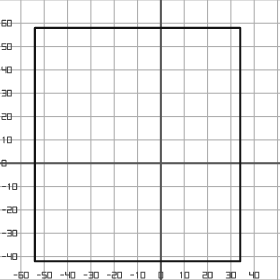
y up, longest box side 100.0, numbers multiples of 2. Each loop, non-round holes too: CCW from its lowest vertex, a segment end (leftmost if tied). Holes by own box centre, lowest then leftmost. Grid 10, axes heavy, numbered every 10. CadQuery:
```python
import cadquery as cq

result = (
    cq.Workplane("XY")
    .moveTo(-54.0, -42.0)
    .lineTo(34.0, -42.0)
    .lineTo(34.0, 58.0)
    .lineTo(-54.0, 58.0)
    .close()
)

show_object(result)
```